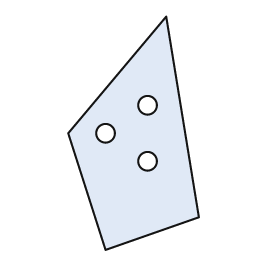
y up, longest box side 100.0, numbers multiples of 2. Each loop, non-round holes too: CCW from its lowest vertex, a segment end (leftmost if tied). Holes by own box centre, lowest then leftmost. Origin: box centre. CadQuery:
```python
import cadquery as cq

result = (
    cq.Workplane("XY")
    .moveTo(-12.0, -50.0)
    .lineTo(28.0, -36.0)
    .lineTo(14.0, 50.0)
    .lineTo(-28.0, 0.0)
    .close()
    .moveTo(6.0, -12.0)
    .circle(4.0)
    .moveTo(-12.0, 0.0)
    .circle(4.0)
    .moveTo(6.0, 12.0)
    .circle(4.0)
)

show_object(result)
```